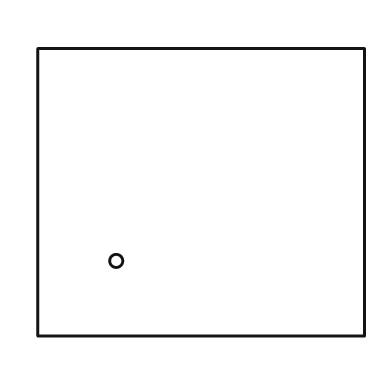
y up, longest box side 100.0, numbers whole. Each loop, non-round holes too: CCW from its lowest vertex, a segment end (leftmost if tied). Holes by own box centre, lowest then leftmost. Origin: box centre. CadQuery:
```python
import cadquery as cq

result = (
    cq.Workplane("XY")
    .moveTo(-50.0, -44.0)
    .lineTo(50.0, -44.0)
    .lineTo(50.0, 44.0)
    .lineTo(-50.0, 44.0)
    .close()
    .moveTo(-26.0, -21.0)
    .circle(2.0)
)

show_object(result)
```